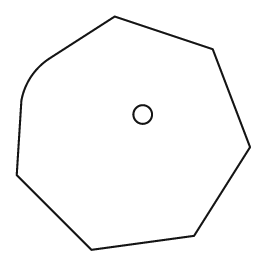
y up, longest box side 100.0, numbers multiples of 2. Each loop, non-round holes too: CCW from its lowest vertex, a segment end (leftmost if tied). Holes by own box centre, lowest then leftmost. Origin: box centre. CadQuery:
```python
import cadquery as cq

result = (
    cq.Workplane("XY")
    .moveTo(-18.0, -50.0)
    .lineTo(26.0, -44.0)
    .lineTo(50.0, -6.0)
    .lineTo(34.0, 36.0)
    .lineTo(-8.0, 50.0)
    .lineTo(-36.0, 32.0)
    .threePointArc((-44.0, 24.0), (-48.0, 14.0))
    .lineTo(-50.0, -18.0)
    .close()
    .moveTo(4.0, 8.0)
    .circle(4.0)
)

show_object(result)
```